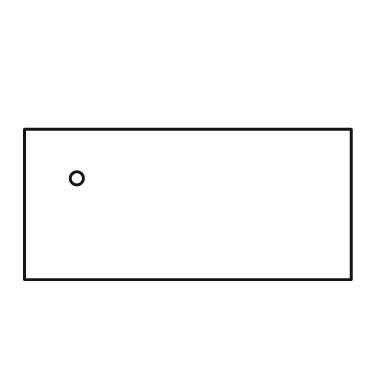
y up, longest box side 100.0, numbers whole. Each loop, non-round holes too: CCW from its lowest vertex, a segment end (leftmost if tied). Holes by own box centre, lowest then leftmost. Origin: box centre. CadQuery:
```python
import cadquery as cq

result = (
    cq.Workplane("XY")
    .moveTo(-50.0, -23.0)
    .lineTo(50.0, -23.0)
    .lineTo(50.0, 23.0)
    .lineTo(-50.0, 23.0)
    .close()
    .moveTo(-34.0, 8.0)
    .circle(2.0)
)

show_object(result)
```